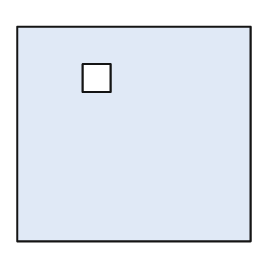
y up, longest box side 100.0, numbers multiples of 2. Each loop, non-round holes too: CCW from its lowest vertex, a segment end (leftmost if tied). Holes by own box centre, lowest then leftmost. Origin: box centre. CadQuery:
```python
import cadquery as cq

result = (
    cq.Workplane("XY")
    .moveTo(-50.0, -46.0)
    .lineTo(50.0, -46.0)
    .lineTo(50.0, 46.0)
    .lineTo(-50.0, 46.0)
    .close()
    .moveTo(-22.0, 18.0)
    .lineTo(-10.0, 18.0)
    .lineTo(-10.0, 30.0)
    .lineTo(-22.0, 30.0)
    .close()
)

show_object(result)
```